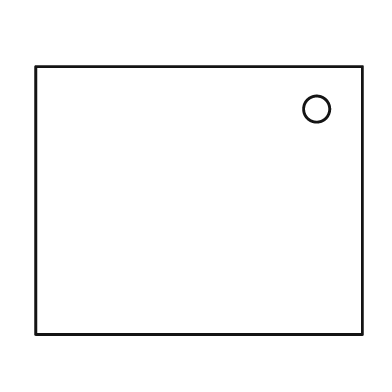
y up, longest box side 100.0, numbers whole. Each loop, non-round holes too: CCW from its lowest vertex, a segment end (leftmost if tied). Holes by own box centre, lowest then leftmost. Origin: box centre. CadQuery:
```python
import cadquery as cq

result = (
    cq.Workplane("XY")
    .moveTo(-50.0, -41.0)
    .lineTo(50.0, -41.0)
    .lineTo(50.0, 41.0)
    .lineTo(-50.0, 41.0)
    .close()
    .moveTo(36.0, 28.0)
    .circle(4.0)
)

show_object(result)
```